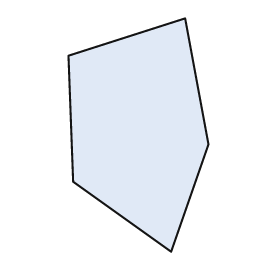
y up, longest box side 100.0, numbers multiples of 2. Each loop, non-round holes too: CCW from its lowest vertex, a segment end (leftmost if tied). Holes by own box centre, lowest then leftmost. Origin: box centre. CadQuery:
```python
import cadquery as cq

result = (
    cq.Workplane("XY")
    .moveTo(14.0, -50.0)
    .lineTo(30.0, -4.0)
    .lineTo(20.0, 50.0)
    .lineTo(-30.0, 34.0)
    .lineTo(-28.0, -20.0)
    .close()
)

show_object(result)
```